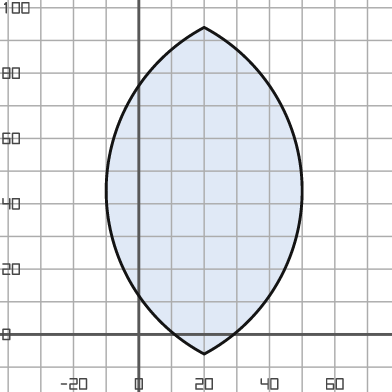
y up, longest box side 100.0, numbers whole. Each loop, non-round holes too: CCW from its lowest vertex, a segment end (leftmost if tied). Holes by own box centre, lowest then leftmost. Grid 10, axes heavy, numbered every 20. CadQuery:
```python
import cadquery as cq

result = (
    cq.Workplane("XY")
    .moveTo(20.0, -6.0)
    .threePointArc((50.0, 44.0), (20.0, 94.0))
    .threePointArc((-10.0, 44.0), (20.0, -6.0))
    .close()
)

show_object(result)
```